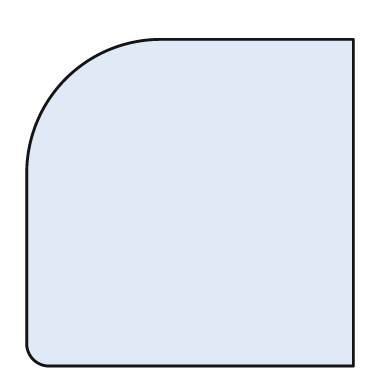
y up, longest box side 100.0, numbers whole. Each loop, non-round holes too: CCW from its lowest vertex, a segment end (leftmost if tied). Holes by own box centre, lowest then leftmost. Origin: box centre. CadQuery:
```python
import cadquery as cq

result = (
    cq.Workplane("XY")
    .moveTo(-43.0, -50.0)
    .lineTo(50.0, -50.0)
    .lineTo(50.0, 50.0)
    .lineTo(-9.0, 50.0)
    .threePointArc((-38.0, 38.0), (-50.0, 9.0))
    .lineTo(-50.0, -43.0)
    .threePointArc((-48.0, -48.0), (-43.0, -50.0))
    .close()
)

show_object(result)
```